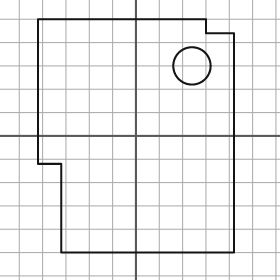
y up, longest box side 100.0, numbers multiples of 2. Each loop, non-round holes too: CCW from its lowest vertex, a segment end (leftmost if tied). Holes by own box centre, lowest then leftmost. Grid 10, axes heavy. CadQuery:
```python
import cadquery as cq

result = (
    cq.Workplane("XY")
    .moveTo(-32.0, -50.0)
    .lineTo(42.0, -50.0)
    .lineTo(42.0, 44.0)
    .lineTo(30.0, 44.0)
    .lineTo(30.0, 50.0)
    .lineTo(-42.0, 50.0)
    .lineTo(-42.0, -12.0)
    .lineTo(-32.0, -12.0)
    .close()
    .moveTo(24.0, 30.0)
    .circle(8.0)
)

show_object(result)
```